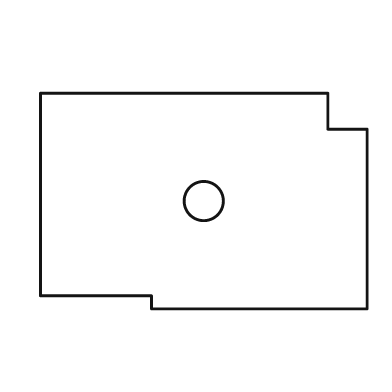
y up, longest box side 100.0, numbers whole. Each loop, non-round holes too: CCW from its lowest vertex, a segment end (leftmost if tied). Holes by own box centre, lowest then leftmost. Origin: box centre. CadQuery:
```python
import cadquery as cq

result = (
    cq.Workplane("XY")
    .moveTo(-16.0, -33.0)
    .lineTo(50.0, -33.0)
    .lineTo(50.0, 22.0)
    .lineTo(38.0, 22.0)
    .lineTo(38.0, 33.0)
    .lineTo(-50.0, 33.0)
    .lineTo(-50.0, -29.0)
    .lineTo(-16.0, -29.0)
    .close()
    .moveTo(0.0, 0.0)
    .circle(6.0)
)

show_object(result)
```